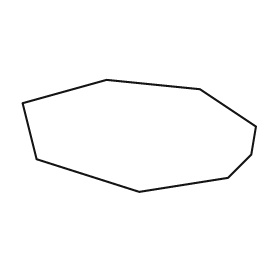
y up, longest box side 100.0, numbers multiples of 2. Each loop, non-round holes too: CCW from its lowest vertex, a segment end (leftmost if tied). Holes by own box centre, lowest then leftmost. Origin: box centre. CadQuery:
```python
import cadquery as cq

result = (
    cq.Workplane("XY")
    .moveTo(0.0, -24.0)
    .lineTo(38.0, -18.0)
    .lineTo(48.0, -8.0)
    .lineTo(50.0, 4.0)
    .lineTo(26.0, 20.0)
    .lineTo(-14.0, 24.0)
    .lineTo(-50.0, 14.0)
    .lineTo(-44.0, -10.0)
    .close()
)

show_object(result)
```